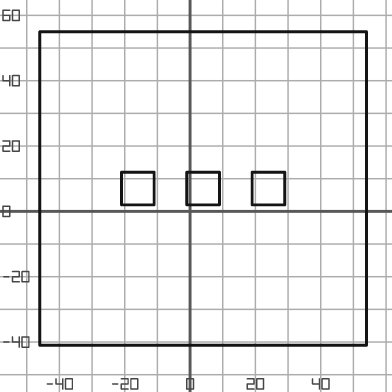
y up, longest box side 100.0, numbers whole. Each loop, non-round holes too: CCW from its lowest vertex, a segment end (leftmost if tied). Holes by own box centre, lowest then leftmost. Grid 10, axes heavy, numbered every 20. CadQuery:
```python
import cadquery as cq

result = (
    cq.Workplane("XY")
    .moveTo(-46.0, -41.0)
    .lineTo(54.0, -41.0)
    .lineTo(54.0, 55.0)
    .lineTo(-46.0, 55.0)
    .close()
    .moveTo(-21.0, 2.0)
    .lineTo(-11.0, 2.0)
    .lineTo(-11.0, 12.0)
    .lineTo(-21.0, 12.0)
    .close()
    .moveTo(-1.0, 2.0)
    .lineTo(9.0, 2.0)
    .lineTo(9.0, 12.0)
    .lineTo(-1.0, 12.0)
    .close()
    .moveTo(19.0, 2.0)
    .lineTo(29.0, 2.0)
    .lineTo(29.0, 12.0)
    .lineTo(19.0, 12.0)
    .close()
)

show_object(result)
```